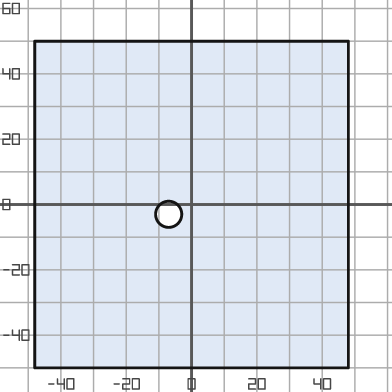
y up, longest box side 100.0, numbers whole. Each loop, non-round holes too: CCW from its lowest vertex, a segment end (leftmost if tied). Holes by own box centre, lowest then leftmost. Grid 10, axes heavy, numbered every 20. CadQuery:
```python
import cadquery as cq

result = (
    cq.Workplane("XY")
    .moveTo(-48.0, -50.0)
    .lineTo(48.0, -50.0)
    .lineTo(48.0, 50.0)
    .lineTo(-48.0, 50.0)
    .close()
    .moveTo(-7.0, -3.0)
    .circle(4.0)
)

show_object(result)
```